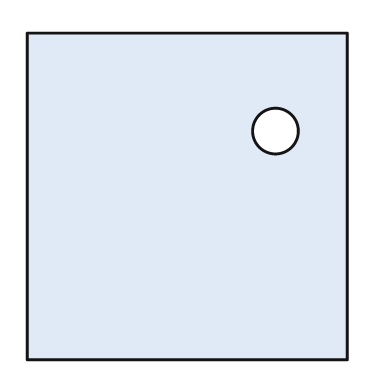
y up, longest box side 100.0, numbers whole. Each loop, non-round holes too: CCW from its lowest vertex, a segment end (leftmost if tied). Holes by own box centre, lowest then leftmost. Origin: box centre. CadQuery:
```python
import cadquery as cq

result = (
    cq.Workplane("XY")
    .moveTo(-49.0, -50.0)
    .lineTo(49.0, -50.0)
    .lineTo(49.0, 50.0)
    .lineTo(-49.0, 50.0)
    .close()
    .moveTo(27.0, 20.0)
    .circle(7.0)
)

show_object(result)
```